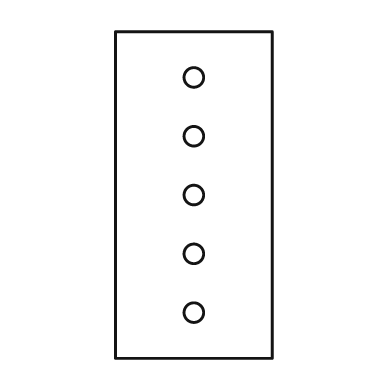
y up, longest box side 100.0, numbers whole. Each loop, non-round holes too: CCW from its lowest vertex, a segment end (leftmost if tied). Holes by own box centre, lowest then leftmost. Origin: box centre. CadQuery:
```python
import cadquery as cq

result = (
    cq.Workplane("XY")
    .moveTo(-24.0, -50.0)
    .lineTo(24.0, -50.0)
    .lineTo(24.0, 50.0)
    .lineTo(-24.0, 50.0)
    .close()
    .moveTo(0.0, -36.0)
    .circle(3.0)
    .moveTo(0.0, -18.0)
    .circle(3.0)
    .moveTo(0.0, 0.0)
    .circle(3.0)
    .moveTo(0.0, 18.0)
    .circle(3.0)
    .moveTo(0.0, 36.0)
    .circle(3.0)
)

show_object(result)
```